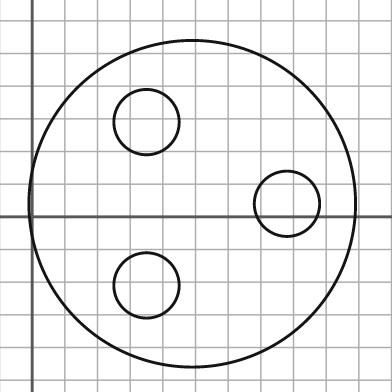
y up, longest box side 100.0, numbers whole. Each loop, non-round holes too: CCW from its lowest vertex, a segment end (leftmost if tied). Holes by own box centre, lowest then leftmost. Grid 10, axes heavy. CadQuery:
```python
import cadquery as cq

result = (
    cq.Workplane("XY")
    .moveTo(49.0, 4.0)
    .circle(50.0)
    .moveTo(35.0, -21.0)
    .circle(10.0)
    .moveTo(78.0, 4.0)
    .circle(10.0)
    .moveTo(35.0, 29.0)
    .circle(10.0)
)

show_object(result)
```